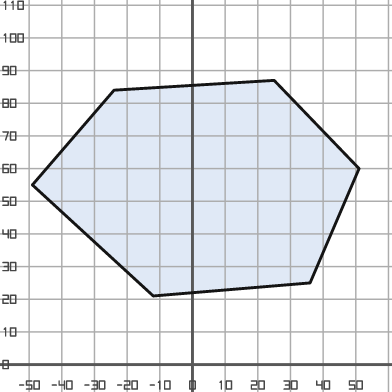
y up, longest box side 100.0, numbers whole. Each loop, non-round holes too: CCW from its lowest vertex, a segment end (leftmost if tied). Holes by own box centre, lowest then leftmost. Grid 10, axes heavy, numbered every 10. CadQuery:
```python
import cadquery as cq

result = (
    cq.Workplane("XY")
    .moveTo(-12.0, 21.0)
    .lineTo(36.0, 25.0)
    .lineTo(51.0, 60.0)
    .lineTo(25.0, 87.0)
    .lineTo(-24.0, 84.0)
    .lineTo(-49.0, 55.0)
    .close()
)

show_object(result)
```